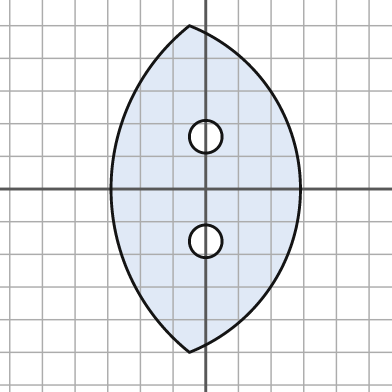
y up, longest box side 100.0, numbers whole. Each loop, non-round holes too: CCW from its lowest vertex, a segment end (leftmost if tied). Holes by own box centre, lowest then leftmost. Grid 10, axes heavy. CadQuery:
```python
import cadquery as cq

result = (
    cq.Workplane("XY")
    .moveTo(-5.0, -50.0)
    .threePointArc((29.0, 0.0), (-5.0, 50.0))
    .threePointArc((-29.0, 0.0), (-5.0, -50.0))
    .close()
    .moveTo(0.0, -16.0)
    .circle(5.0)
    .moveTo(0.0, 16.0)
    .circle(5.0)
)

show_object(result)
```